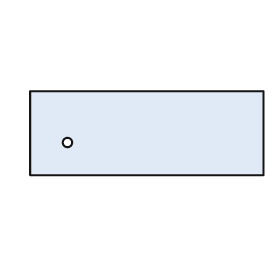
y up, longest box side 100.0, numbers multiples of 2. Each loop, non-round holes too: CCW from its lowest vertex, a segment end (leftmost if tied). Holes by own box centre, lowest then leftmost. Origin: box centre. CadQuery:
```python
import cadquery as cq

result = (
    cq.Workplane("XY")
    .moveTo(-50.0, -18.0)
    .lineTo(50.0, -18.0)
    .lineTo(50.0, 18.0)
    .lineTo(-50.0, 18.0)
    .close()
    .moveTo(-34.0, -4.0)
    .circle(2.0)
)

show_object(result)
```